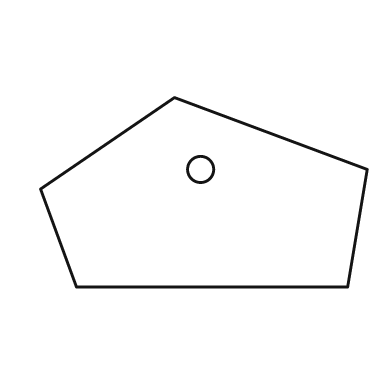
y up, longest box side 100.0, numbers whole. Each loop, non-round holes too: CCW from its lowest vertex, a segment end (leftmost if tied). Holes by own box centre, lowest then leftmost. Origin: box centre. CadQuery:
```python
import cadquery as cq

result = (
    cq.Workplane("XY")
    .moveTo(-39.0, -29.0)
    .lineTo(44.0, -29.0)
    .lineTo(50.0, 7.0)
    .lineTo(-9.0, 29.0)
    .lineTo(-50.0, 1.0)
    .close()
    .moveTo(-1.0, 7.0)
    .circle(4.0)
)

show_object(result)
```